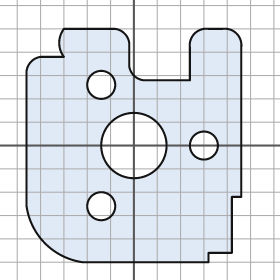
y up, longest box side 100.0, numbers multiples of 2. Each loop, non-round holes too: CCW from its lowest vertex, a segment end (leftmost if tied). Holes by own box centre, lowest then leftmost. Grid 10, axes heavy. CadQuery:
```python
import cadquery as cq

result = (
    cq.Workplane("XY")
    .moveTo(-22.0, -50.0)
    .lineTo(32.0, -50.0)
    .lineTo(32.0, -46.0)
    .lineTo(42.0, -46.0)
    .lineTo(42.0, -22.0)
    .lineTo(46.0, -22.0)
    .lineTo(46.0, 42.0)
    .threePointArc((44.0, 48.0), (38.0, 50.0))
    .lineTo(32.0, 50.0)
    .threePointArc((26.0, 48.0), (24.0, 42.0))
    .lineTo(24.0, 28.0)
    .lineTo(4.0, 28.0)
    .threePointArc((0.0, 30.0), (-2.0, 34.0))
    .lineTo(-2.0, 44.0)
    .threePointArc((-4.0, 48.0), (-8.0, 50.0))
    .lineTo(-30.0, 50.0)
    .threePointArc((-32.0, 44.0), (-30.0, 38.0))
    .lineTo(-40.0, 38.0)
    .threePointArc((-44.0, 36.0), (-46.0, 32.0))
    .lineTo(-46.0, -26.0)
    .threePointArc((-38.0, -42.0), (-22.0, -50.0))
    .close()
    .moveTo(-14.0, -26.0)
    .circle(6.0)
    .moveTo(0.0, 0.0)
    .circle(14.0)
    .moveTo(30.0, 0.0)
    .circle(6.0)
    .moveTo(-14.0, 26.0)
    .circle(6.0)
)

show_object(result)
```